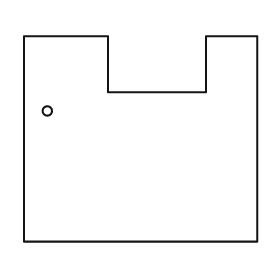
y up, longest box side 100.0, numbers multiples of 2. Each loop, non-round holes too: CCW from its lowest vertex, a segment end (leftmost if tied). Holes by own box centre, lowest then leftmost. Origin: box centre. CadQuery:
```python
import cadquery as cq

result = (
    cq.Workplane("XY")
    .moveTo(-50.0, -44.0)
    .lineTo(50.0, -44.0)
    .lineTo(50.0, 44.0)
    .lineTo(28.0, 44.0)
    .lineTo(28.0, 20.0)
    .lineTo(-14.0, 20.0)
    .lineTo(-14.0, 44.0)
    .lineTo(-50.0, 44.0)
    .close()
    .moveTo(-40.0, 12.0)
    .circle(2.0)
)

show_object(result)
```